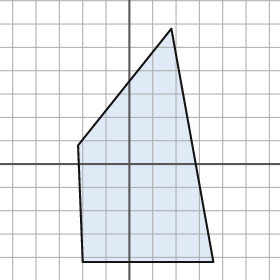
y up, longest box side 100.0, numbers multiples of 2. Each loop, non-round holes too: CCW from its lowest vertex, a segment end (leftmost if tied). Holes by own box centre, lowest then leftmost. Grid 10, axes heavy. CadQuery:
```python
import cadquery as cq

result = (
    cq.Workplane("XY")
    .moveTo(-20.0, -42.0)
    .lineTo(36.0, -42.0)
    .lineTo(18.0, 58.0)
    .lineTo(-22.0, 8.0)
    .close()
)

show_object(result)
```